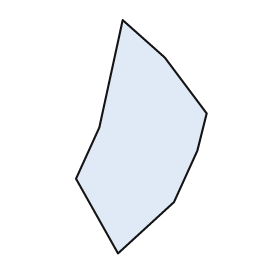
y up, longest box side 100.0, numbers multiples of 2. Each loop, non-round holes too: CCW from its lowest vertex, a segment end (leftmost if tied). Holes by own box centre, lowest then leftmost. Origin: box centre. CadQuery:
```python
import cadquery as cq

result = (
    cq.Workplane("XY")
    .moveTo(-10.0, -50.0)
    .lineTo(14.0, -28.0)
    .lineTo(24.0, -6.0)
    .lineTo(28.0, 10.0)
    .lineTo(10.0, 34.0)
    .lineTo(-8.0, 50.0)
    .lineTo(-18.0, 4.0)
    .lineTo(-28.0, -18.0)
    .close()
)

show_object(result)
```